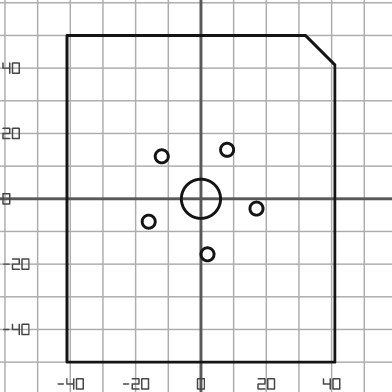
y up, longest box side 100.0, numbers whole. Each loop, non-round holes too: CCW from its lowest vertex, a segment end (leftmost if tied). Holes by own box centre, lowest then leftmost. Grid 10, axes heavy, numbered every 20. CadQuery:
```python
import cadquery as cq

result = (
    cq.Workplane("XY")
    .moveTo(-41.0, -50.0)
    .lineTo(41.0, -50.0)
    .lineTo(41.0, 41.0)
    .lineTo(32.0, 50.0)
    .lineTo(-41.0, 50.0)
    .close()
    .moveTo(2.0, -17.0)
    .circle(2.0)
    .moveTo(-16.0, -7.0)
    .circle(2.0)
    .moveTo(17.0, -3.0)
    .circle(2.0)
    .moveTo(0.0, 0.0)
    .circle(6.0)
    .moveTo(-12.0, 13.0)
    .circle(2.0)
    .moveTo(8.0, 15.0)
    .circle(2.0)
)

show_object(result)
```